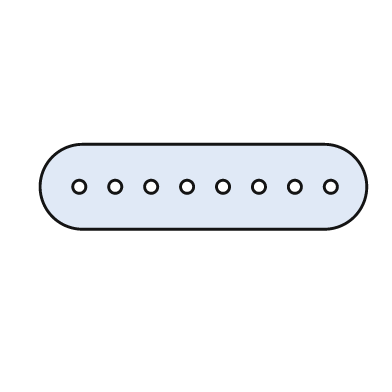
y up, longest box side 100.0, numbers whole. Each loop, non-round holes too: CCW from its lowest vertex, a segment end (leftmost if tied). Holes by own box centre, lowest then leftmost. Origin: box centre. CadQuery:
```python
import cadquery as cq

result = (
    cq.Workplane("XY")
    .moveTo(-37.0, -13.0)
    .lineTo(37.0, -13.0)
    .threePointArc((50.0, 0.0), (37.0, 13.0))
    .lineTo(-37.0, 13.0)
    .threePointArc((-50.0, 0.0), (-37.0, -13.0))
    .close()
    .moveTo(-38.0, 0.0)
    .circle(2.0)
    .moveTo(-27.0, 0.0)
    .circle(2.0)
    .moveTo(-16.0, 0.0)
    .circle(2.0)
    .moveTo(-5.0, 0.0)
    .circle(2.0)
    .moveTo(6.0, 0.0)
    .circle(2.0)
    .moveTo(17.0, 0.0)
    .circle(2.0)
    .moveTo(28.0, 0.0)
    .circle(2.0)
    .moveTo(39.0, 0.0)
    .circle(2.0)
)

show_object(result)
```